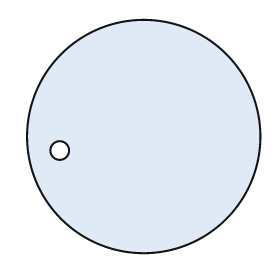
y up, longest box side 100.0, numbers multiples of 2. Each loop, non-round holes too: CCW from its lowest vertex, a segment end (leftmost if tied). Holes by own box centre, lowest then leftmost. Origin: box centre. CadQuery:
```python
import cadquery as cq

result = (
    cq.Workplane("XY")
    .moveTo(0.0, 0.0)
    .circle(50.0)
    .moveTo(-36.0, -6.0)
    .circle(4.0)
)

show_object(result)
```